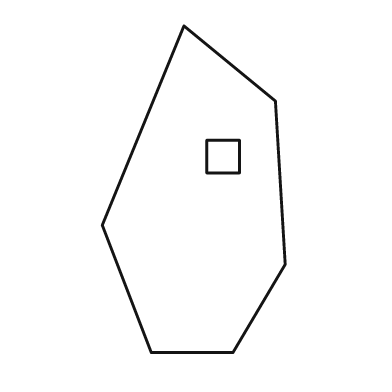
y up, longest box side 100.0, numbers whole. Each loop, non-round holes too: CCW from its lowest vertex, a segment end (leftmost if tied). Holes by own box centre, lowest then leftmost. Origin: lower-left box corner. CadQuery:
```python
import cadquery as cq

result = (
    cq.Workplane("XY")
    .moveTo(15.0, 0.0)
    .lineTo(40.0, 0.0)
    .lineTo(56.0, 27.0)
    .lineTo(53.0, 77.0)
    .lineTo(25.0, 100.0)
    .lineTo(0.0, 39.0)
    .close()
    .moveTo(32.0, 55.0)
    .lineTo(42.0, 55.0)
    .lineTo(42.0, 65.0)
    .lineTo(32.0, 65.0)
    .close()
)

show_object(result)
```